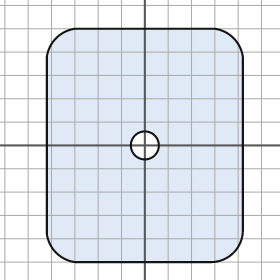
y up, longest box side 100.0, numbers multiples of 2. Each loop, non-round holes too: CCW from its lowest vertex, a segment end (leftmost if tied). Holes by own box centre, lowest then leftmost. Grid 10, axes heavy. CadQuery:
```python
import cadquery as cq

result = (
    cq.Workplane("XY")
    .moveTo(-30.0, -50.0)
    .lineTo(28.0, -50.0)
    .threePointArc((38.0, -46.0), (42.0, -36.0))
    .lineTo(42.0, 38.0)
    .threePointArc((38.0, 46.0), (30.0, 50.0))
    .lineTo(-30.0, 50.0)
    .threePointArc((-38.0, 46.0), (-42.0, 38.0))
    .lineTo(-42.0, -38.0)
    .threePointArc((-38.0, -46.0), (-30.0, -50.0))
    .close()
    .moveTo(0.0, 0.0)
    .circle(6.0)
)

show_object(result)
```